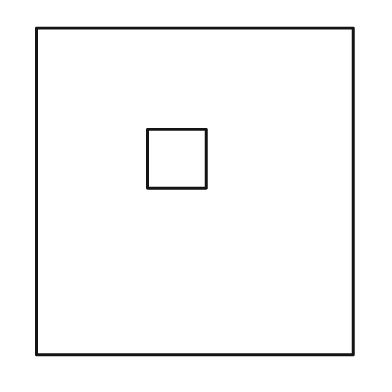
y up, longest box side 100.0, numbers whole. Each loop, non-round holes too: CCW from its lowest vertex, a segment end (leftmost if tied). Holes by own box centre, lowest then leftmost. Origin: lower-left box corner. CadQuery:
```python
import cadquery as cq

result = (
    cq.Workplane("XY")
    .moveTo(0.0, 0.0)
    .lineTo(97.0, 0.0)
    .lineTo(97.0, 100.0)
    .lineTo(0.0, 100.0)
    .close()
    .moveTo(34.0, 51.0)
    .lineTo(52.0, 51.0)
    .lineTo(52.0, 69.0)
    .lineTo(34.0, 69.0)
    .close()
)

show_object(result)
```